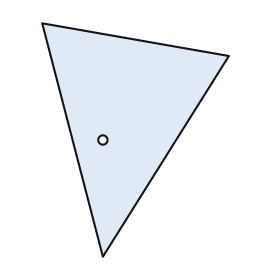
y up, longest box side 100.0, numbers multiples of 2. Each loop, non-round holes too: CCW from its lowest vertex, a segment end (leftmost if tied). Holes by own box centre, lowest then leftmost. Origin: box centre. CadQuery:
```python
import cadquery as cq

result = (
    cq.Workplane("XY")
    .moveTo(-14.0, -50.0)
    .lineTo(40.0, 36.0)
    .lineTo(-40.0, 50.0)
    .close()
    .moveTo(-14.0, 0.0)
    .circle(2.0)
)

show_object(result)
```